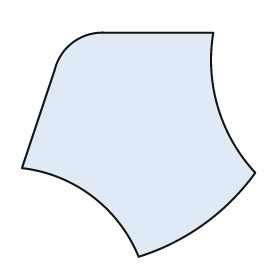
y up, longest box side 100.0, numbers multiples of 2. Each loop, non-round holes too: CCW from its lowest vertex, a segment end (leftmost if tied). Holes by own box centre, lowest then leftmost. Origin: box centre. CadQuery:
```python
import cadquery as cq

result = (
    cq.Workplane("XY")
    .moveTo(0.0, -48.0)
    .threePointArc((28.0, -34.0), (50.0, -12.0))
    .threePointArc((34.0, 16.0), (32.0, 48.0))
    .lineTo(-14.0, 48.0)
    .threePointArc((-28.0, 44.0), (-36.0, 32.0))
    .lineTo(-50.0, -10.0)
    .threePointArc((-20.0, -22.0), (0.0, -48.0))
    .close()
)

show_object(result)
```